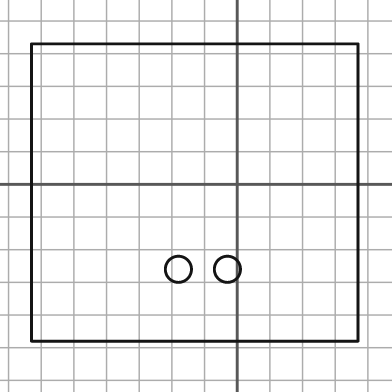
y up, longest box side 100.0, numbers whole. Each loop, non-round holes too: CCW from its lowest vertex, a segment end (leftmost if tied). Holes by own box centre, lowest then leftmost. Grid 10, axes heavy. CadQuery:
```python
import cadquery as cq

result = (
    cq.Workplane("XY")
    .moveTo(-63.0, -48.0)
    .lineTo(37.0, -48.0)
    .lineTo(37.0, 43.0)
    .lineTo(-63.0, 43.0)
    .close()
    .moveTo(-18.0, -26.0)
    .circle(4.0)
    .moveTo(-3.0, -26.0)
    .circle(4.0)
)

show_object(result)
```